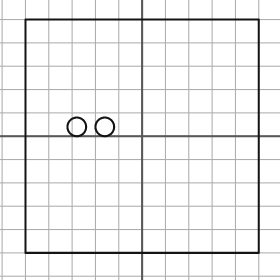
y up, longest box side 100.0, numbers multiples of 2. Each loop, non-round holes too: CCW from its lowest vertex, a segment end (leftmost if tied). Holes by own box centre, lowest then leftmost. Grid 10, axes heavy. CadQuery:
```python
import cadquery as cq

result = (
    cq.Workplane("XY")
    .moveTo(-50.0, -50.0)
    .lineTo(50.0, -50.0)
    .lineTo(50.0, 50.0)
    .lineTo(-50.0, 50.0)
    .close()
    .moveTo(-28.0, 4.0)
    .circle(4.0)
    .moveTo(-16.0, 4.0)
    .circle(4.0)
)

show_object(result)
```